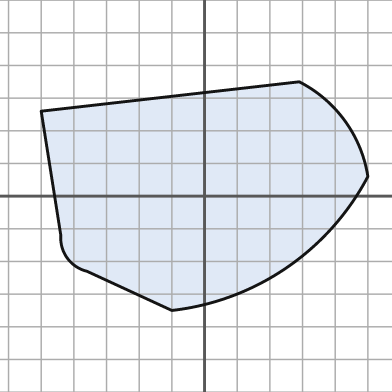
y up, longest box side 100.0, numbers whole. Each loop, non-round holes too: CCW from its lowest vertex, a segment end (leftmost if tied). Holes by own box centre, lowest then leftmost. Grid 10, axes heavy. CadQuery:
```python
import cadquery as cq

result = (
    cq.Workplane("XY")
    .moveTo(-10.0, -35.0)
    .threePointArc((25.0, -22.0), (50.0, 6.0))
    .threePointArc((43.0, 23.0), (29.0, 35.0))
    .lineTo(-50.0, 26.0)
    .lineTo(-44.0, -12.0)
    .threePointArc((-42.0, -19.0), (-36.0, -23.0))
    .close()
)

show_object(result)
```